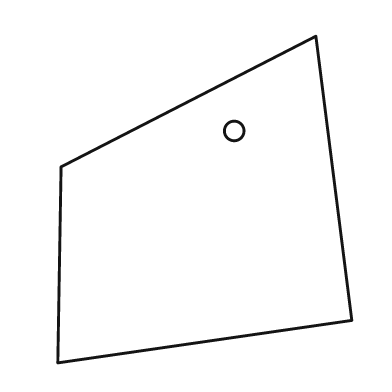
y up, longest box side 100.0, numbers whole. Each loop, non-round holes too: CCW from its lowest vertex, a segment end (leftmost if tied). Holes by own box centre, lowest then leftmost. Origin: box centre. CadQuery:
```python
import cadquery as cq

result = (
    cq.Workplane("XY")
    .moveTo(-45.0, -50.0)
    .lineTo(45.0, -37.0)
    .lineTo(34.0, 50.0)
    .lineTo(-44.0, 10.0)
    .close()
    .moveTo(9.0, 21.0)
    .circle(3.0)
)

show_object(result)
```